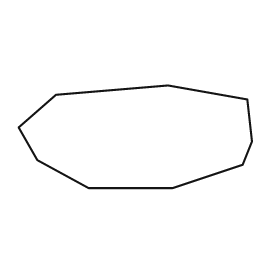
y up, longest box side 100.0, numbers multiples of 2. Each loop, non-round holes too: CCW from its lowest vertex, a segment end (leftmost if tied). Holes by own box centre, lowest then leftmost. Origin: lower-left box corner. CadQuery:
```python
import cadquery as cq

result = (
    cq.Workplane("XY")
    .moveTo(30.0, 0.0)
    .lineTo(66.0, 0.0)
    .lineTo(96.0, 10.0)
    .lineTo(100.0, 20.0)
    .lineTo(98.0, 38.0)
    .lineTo(64.0, 44.0)
    .lineTo(16.0, 40.0)
    .lineTo(0.0, 26.0)
    .lineTo(8.0, 12.0)
    .close()
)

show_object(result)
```